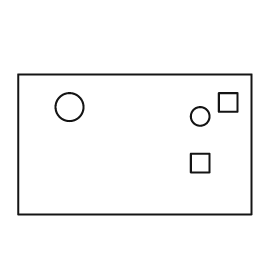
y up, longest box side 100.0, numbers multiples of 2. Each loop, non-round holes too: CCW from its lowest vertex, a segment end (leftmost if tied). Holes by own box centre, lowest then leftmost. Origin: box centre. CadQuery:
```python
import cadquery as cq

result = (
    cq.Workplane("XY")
    .moveTo(-50.0, -30.0)
    .lineTo(50.0, -30.0)
    .lineTo(50.0, 30.0)
    .lineTo(-50.0, 30.0)
    .close()
    .moveTo(24.0, -12.0)
    .lineTo(32.0, -12.0)
    .lineTo(32.0, -4.0)
    .lineTo(24.0, -4.0)
    .close()
    .moveTo(28.0, 12.0)
    .circle(4.0)
    .moveTo(-28.0, 16.0)
    .circle(6.0)
    .moveTo(36.0, 14.0)
    .lineTo(44.0, 14.0)
    .lineTo(44.0, 22.0)
    .lineTo(36.0, 22.0)
    .close()
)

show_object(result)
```